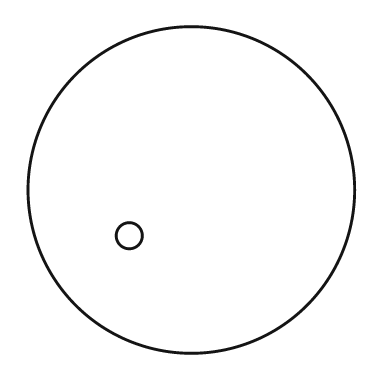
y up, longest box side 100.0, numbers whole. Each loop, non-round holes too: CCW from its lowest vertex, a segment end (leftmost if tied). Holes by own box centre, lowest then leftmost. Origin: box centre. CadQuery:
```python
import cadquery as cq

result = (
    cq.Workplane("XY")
    .moveTo(0.0, 0.0)
    .circle(50.0)
    .moveTo(-19.0, -14.0)
    .circle(4.0)
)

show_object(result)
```